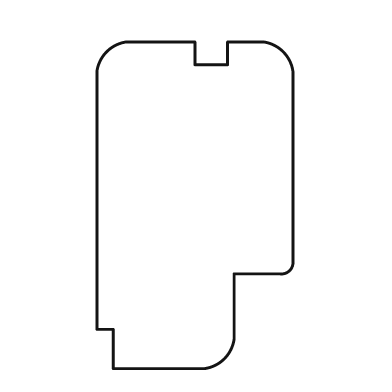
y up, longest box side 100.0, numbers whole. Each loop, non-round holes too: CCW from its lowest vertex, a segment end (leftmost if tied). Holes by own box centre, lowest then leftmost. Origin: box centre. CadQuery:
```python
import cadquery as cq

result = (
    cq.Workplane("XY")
    .moveTo(-25.0, -50.0)
    .lineTo(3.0, -50.0)
    .threePointArc((9.0, -47.0), (12.0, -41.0))
    .lineTo(12.0, -21.0)
    .lineTo(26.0, -21.0)
    .threePointArc((29.0, -20.0), (30.0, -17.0))
    .lineTo(30.0, 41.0)
    .threePointArc((27.0, 47.0), (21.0, 50.0))
    .lineTo(10.0, 50.0)
    .lineTo(10.0, 43.0)
    .lineTo(0.0, 43.0)
    .lineTo(0.0, 50.0)
    .lineTo(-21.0, 50.0)
    .threePointArc((-27.0, 47.0), (-30.0, 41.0))
    .lineTo(-30.0, -38.0)
    .lineTo(-25.0, -38.0)
    .close()
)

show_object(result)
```